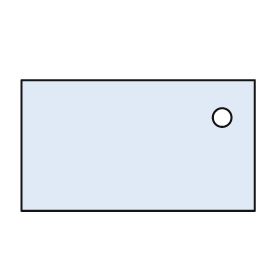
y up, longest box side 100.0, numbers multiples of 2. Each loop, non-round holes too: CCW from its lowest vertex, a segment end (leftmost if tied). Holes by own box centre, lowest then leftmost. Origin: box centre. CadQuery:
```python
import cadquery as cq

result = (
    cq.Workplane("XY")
    .moveTo(-50.0, -28.0)
    .lineTo(50.0, -28.0)
    .lineTo(50.0, 28.0)
    .lineTo(-50.0, 28.0)
    .close()
    .moveTo(36.0, 12.0)
    .circle(4.0)
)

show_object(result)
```